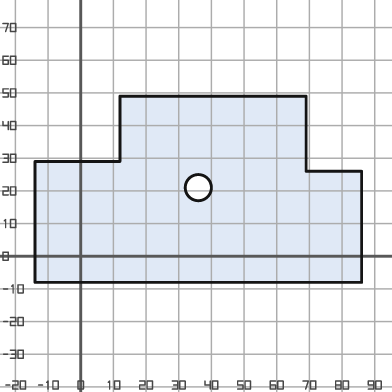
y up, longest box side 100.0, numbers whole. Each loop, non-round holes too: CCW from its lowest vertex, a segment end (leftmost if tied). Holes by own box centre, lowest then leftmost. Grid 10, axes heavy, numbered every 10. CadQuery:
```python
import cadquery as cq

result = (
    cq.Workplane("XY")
    .moveTo(-14.0, -8.0)
    .lineTo(86.0, -8.0)
    .lineTo(86.0, 26.0)
    .lineTo(69.0, 26.0)
    .lineTo(69.0, 49.0)
    .lineTo(12.0, 49.0)
    .lineTo(12.0, 29.0)
    .lineTo(-14.0, 29.0)
    .close()
    .moveTo(36.0, 21.0)
    .circle(4.0)
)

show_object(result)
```